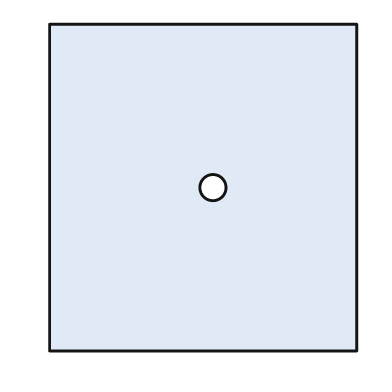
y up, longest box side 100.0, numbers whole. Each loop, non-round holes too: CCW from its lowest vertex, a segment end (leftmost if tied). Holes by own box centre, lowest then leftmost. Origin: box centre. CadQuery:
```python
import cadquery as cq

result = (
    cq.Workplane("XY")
    .moveTo(-47.0, -50.0)
    .lineTo(47.0, -50.0)
    .lineTo(47.0, 50.0)
    .lineTo(-47.0, 50.0)
    .close()
    .moveTo(3.0, 0.0)
    .circle(4.0)
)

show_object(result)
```